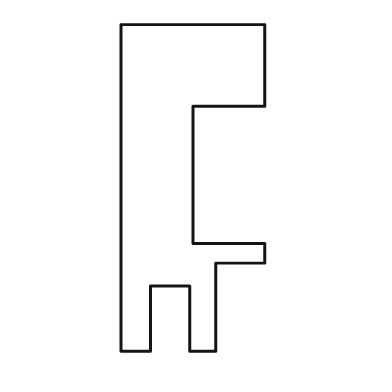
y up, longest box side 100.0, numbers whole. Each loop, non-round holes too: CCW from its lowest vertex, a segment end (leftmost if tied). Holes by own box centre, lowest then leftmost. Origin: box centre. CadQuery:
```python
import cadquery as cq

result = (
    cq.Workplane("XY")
    .moveTo(-22.0, -50.0)
    .lineTo(-13.0, -50.0)
    .lineTo(-13.0, -30.0)
    .lineTo(-1.0, -30.0)
    .lineTo(-1.0, -50.0)
    .lineTo(7.0, -50.0)
    .lineTo(7.0, -23.0)
    .lineTo(22.0, -23.0)
    .lineTo(22.0, -17.0)
    .lineTo(0.0, -17.0)
    .lineTo(0.0, 25.0)
    .lineTo(22.0, 25.0)
    .lineTo(22.0, 50.0)
    .lineTo(-22.0, 50.0)
    .close()
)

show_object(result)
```